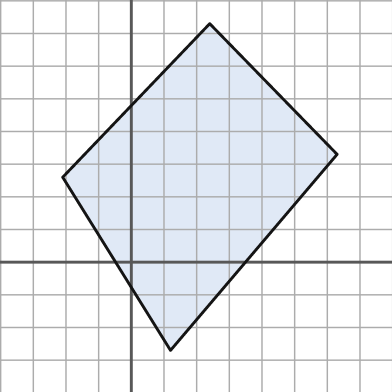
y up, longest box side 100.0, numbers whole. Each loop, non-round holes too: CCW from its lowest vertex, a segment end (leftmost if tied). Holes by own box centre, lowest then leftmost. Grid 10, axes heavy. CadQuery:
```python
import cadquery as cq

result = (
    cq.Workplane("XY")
    .moveTo(12.0, -27.0)
    .lineTo(63.0, 33.0)
    .lineTo(24.0, 73.0)
    .lineTo(-21.0, 26.0)
    .close()
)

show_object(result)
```